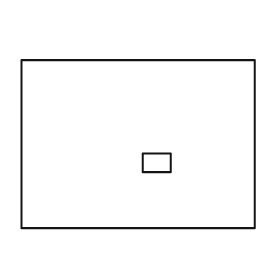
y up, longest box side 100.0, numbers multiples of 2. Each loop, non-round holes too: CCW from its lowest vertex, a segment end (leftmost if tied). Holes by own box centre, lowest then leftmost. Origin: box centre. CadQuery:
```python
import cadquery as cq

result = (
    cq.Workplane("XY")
    .moveTo(-50.0, -36.0)
    .lineTo(50.0, -36.0)
    .lineTo(50.0, 36.0)
    .lineTo(-50.0, 36.0)
    .close()
    .moveTo(2.0, -12.0)
    .lineTo(14.0, -12.0)
    .lineTo(14.0, -4.0)
    .lineTo(2.0, -4.0)
    .close()
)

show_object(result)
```